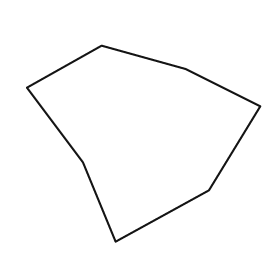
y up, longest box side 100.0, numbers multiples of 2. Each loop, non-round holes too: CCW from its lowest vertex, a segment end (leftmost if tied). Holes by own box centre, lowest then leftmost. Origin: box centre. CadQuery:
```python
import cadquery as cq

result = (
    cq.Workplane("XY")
    .moveTo(-12.0, -42.0)
    .lineTo(28.0, -20.0)
    .lineTo(50.0, 16.0)
    .lineTo(18.0, 32.0)
    .lineTo(-18.0, 42.0)
    .lineTo(-50.0, 24.0)
    .lineTo(-26.0, -8.0)
    .close()
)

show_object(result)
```